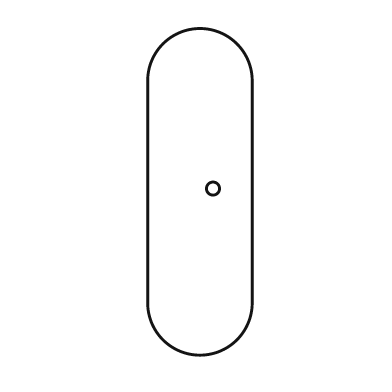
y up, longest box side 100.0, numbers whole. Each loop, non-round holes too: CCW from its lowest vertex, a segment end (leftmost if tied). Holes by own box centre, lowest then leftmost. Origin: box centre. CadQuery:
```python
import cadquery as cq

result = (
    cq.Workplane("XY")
    .moveTo(-16.0, -34.0)
    .threePointArc((0.0, -50.0), (16.0, -34.0))
    .lineTo(16.0, 34.0)
    .threePointArc((0.0, 50.0), (-16.0, 34.0))
    .close()
    .moveTo(4.0, 1.0)
    .circle(2.0)
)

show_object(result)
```